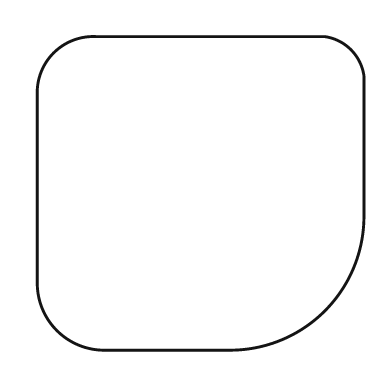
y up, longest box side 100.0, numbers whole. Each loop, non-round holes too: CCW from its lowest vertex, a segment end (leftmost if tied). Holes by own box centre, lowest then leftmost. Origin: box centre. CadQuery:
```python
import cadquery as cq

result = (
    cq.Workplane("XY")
    .moveTo(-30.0, -48.0)
    .lineTo(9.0, -48.0)
    .threePointArc((38.0, -36.0), (50.0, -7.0))
    .lineTo(50.0, 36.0)
    .threePointArc((46.0, 44.0), (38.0, 48.0))
    .lineTo(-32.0, 48.0)
    .threePointArc((-45.0, 43.0), (-50.0, 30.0))
    .lineTo(-50.0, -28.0)
    .threePointArc((-44.0, -42.0), (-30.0, -48.0))
    .close()
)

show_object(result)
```